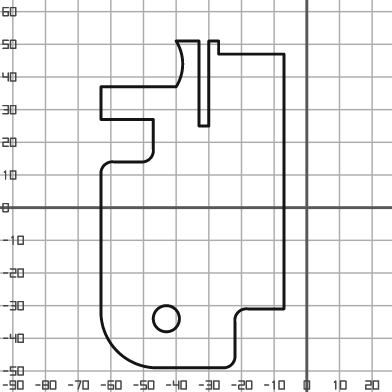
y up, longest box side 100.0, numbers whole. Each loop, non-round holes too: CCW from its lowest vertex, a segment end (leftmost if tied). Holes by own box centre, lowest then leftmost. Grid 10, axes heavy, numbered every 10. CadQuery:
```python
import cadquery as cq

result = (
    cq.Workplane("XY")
    .moveTo(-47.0, -49.0)
    .lineTo(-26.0, -49.0)
    .threePointArc((-23.0, -48.0), (-22.0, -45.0))
    .lineTo(-22.0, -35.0)
    .threePointArc((-21.0, -32.0), (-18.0, -31.0))
    .lineTo(-7.0, -31.0)
    .lineTo(-7.0, 47.0)
    .lineTo(-27.0, 47.0)
    .lineTo(-27.0, 51.0)
    .lineTo(-30.0, 51.0)
    .lineTo(-30.0, 25.0)
    .lineTo(-33.0, 25.0)
    .lineTo(-33.0, 51.0)
    .lineTo(-40.0, 51.0)
    .threePointArc((-38.0, 44.0), (-40.0, 37.0))
    .lineTo(-63.0, 37.0)
    .lineTo(-63.0, 27.0)
    .lineTo(-47.0, 27.0)
    .lineTo(-47.0, 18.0)
    .threePointArc((-48.0, 15.0), (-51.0, 14.0))
    .lineTo(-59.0, 14.0)
    .threePointArc((-62.0, 13.0), (-63.0, 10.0))
    .lineTo(-63.0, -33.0)
    .threePointArc((-58.0, -44.0), (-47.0, -49.0))
    .close()
    .moveTo(-43.0, -34.0)
    .circle(4.0)
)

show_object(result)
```